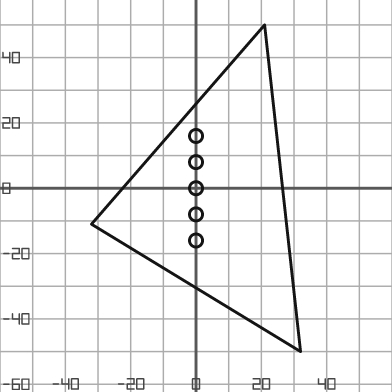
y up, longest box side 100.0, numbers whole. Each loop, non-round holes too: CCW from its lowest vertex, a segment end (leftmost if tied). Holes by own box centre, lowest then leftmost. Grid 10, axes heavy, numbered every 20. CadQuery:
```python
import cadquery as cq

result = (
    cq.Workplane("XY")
    .moveTo(32.0, -50.0)
    .lineTo(21.0, 50.0)
    .lineTo(-32.0, -11.0)
    .close()
    .moveTo(0.0, -16.0)
    .circle(2.0)
    .moveTo(0.0, -8.0)
    .circle(2.0)
    .moveTo(0.0, 0.0)
    .circle(2.0)
    .moveTo(0.0, 8.0)
    .circle(2.0)
    .moveTo(0.0, 16.0)
    .circle(2.0)
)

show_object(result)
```